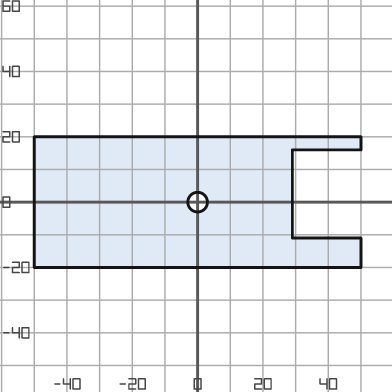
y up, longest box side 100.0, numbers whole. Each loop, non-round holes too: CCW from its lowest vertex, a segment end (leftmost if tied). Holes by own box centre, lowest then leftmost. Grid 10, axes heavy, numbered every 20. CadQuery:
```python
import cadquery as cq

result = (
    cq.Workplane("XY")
    .moveTo(-50.0, -20.0)
    .lineTo(50.0, -20.0)
    .lineTo(50.0, -11.0)
    .lineTo(29.0, -11.0)
    .lineTo(29.0, 16.0)
    .lineTo(50.0, 16.0)
    .lineTo(50.0, 20.0)
    .lineTo(-50.0, 20.0)
    .close()
    .moveTo(0.0, 0.0)
    .circle(3.0)
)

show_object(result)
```